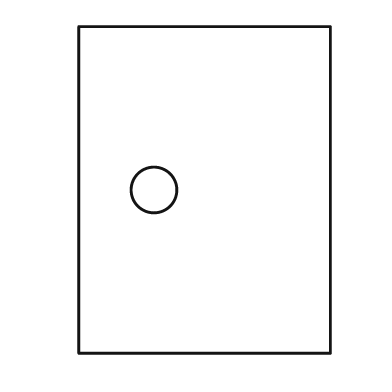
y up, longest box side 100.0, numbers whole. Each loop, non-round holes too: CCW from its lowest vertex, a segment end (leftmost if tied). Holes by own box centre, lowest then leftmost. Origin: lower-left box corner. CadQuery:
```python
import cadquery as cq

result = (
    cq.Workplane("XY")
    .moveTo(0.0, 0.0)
    .lineTo(77.0, 0.0)
    .lineTo(77.0, 100.0)
    .lineTo(0.0, 100.0)
    .close()
    .moveTo(23.0, 50.0)
    .circle(7.0)
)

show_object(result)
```